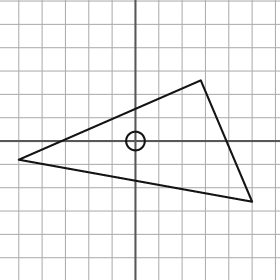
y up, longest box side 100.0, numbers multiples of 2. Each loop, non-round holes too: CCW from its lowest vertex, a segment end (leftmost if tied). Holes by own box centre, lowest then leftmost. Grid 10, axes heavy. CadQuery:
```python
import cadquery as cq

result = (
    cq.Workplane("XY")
    .moveTo(50.0, -26.0)
    .lineTo(28.0, 26.0)
    .lineTo(-50.0, -8.0)
    .close()
    .moveTo(0.0, 0.0)
    .circle(4.0)
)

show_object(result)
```